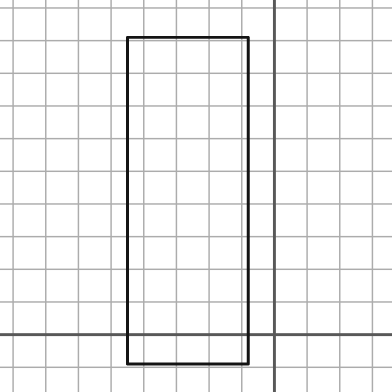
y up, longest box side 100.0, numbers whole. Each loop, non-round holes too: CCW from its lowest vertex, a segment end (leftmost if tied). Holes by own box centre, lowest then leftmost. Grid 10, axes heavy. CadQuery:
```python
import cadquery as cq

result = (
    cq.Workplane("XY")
    .moveTo(-45.0, -9.0)
    .lineTo(-8.0, -9.0)
    .lineTo(-8.0, 91.0)
    .lineTo(-45.0, 91.0)
    .close()
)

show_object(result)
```